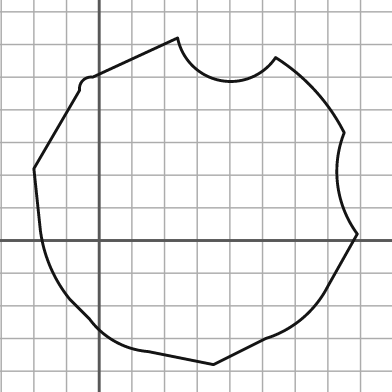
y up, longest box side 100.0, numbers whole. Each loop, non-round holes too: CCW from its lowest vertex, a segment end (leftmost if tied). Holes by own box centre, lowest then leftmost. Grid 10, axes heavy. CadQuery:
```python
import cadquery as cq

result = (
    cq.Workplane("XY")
    .moveTo(35.0, -38.0)
    .lineTo(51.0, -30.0)
    .threePointArc((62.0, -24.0), (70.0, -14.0))
    .lineTo(79.0, 2.0)
    .threePointArc((73.0, 17.0), (75.0, 33.0))
    .threePointArc((66.0, 46.0), (54.0, 56.0))
    .threePointArc((37.0, 49.0), (24.0, 62.0))
    .lineTo(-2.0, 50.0)
    .threePointArc((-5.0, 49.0), (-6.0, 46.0))
    .lineTo(-20.0, 22.0)
    .lineTo(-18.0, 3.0)
    .threePointArc((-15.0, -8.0), (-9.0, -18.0))
    .lineTo(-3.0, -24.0)
    .threePointArc((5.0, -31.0), (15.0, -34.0))
    .close()
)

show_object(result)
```